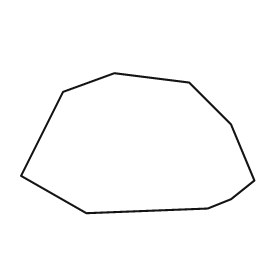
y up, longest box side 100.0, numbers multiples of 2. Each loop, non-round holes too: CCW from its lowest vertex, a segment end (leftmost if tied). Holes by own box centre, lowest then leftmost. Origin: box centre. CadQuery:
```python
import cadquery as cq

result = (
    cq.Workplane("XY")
    .moveTo(-22.0, -30.0)
    .lineTo(30.0, -28.0)
    .lineTo(40.0, -24.0)
    .lineTo(50.0, -16.0)
    .lineTo(40.0, 8.0)
    .lineTo(22.0, 26.0)
    .lineTo(-10.0, 30.0)
    .lineTo(-32.0, 22.0)
    .lineTo(-50.0, -14.0)
    .close()
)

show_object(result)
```